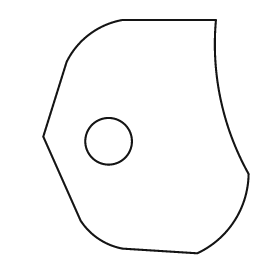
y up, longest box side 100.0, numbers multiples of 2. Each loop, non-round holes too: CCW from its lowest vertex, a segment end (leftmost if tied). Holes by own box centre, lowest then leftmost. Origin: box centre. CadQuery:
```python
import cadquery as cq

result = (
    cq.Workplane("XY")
    .moveTo(22.0, -50.0)
    .threePointArc((38.0, -36.0), (44.0, -16.0))
    .threePointArc((32.0, 16.0), (30.0, 50.0))
    .lineTo(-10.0, 50.0)
    .threePointArc((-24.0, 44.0), (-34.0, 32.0))
    .lineTo(-44.0, 0.0)
    .lineTo(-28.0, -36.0)
    .threePointArc((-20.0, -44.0), (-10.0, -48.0))
    .close()
    .moveTo(-16.0, -2.0)
    .circle(10.0)
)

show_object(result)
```